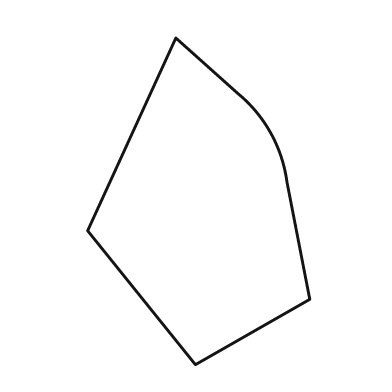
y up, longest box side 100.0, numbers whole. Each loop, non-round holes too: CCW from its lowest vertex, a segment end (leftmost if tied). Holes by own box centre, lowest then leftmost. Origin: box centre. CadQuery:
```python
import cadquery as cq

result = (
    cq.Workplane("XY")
    .moveTo(-1.0, -50.0)
    .lineTo(34.0, -30.0)
    .lineTo(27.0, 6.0)
    .threePointArc((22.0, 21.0), (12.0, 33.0))
    .lineTo(-7.0, 50.0)
    .lineTo(-34.0, -9.0)
    .close()
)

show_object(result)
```